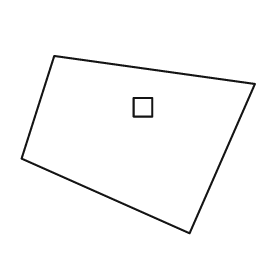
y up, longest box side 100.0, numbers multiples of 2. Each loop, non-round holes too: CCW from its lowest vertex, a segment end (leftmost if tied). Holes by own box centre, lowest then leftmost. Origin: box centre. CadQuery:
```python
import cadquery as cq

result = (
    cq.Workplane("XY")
    .moveTo(22.0, -38.0)
    .lineTo(50.0, 26.0)
    .lineTo(-36.0, 38.0)
    .lineTo(-50.0, -6.0)
    .close()
    .moveTo(-2.0, 12.0)
    .lineTo(6.0, 12.0)
    .lineTo(6.0, 20.0)
    .lineTo(-2.0, 20.0)
    .close()
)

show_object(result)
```